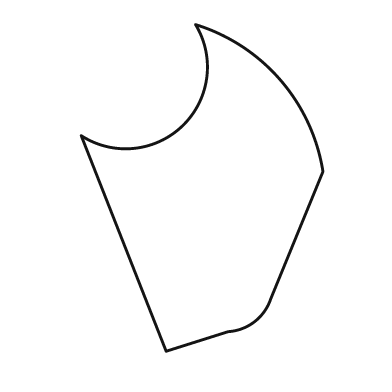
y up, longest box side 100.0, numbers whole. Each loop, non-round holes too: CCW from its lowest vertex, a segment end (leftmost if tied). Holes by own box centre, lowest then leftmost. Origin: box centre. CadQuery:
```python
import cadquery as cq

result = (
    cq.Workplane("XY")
    .moveTo(-11.0, -50.0)
    .lineTo(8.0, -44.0)
    .threePointArc((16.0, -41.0), (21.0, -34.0))
    .lineTo(37.0, 5.0)
    .threePointArc((24.0, 33.0), (-2.0, 50.0))
    .threePointArc((-6.0, 19.0), (-37.0, 16.0))
    .close()
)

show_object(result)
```